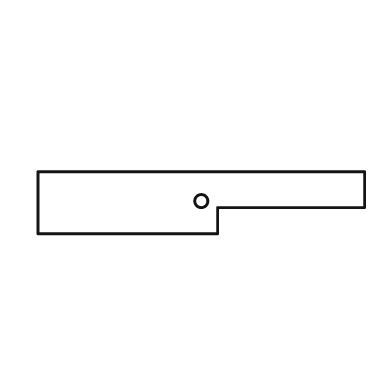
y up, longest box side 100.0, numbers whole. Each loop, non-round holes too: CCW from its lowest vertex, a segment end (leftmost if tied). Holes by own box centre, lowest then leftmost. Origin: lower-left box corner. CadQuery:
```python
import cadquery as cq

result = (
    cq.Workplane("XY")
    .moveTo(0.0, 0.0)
    .lineTo(55.0, 0.0)
    .lineTo(55.0, 8.0)
    .lineTo(100.0, 8.0)
    .lineTo(100.0, 19.0)
    .lineTo(0.0, 19.0)
    .close()
    .moveTo(50.0, 10.0)
    .circle(2.0)
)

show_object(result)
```